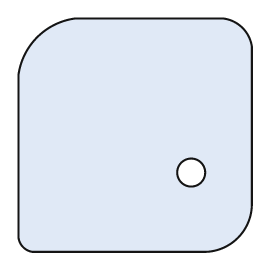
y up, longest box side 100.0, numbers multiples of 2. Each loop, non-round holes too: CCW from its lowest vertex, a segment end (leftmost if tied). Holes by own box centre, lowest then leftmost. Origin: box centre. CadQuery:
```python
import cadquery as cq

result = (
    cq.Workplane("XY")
    .moveTo(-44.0, -50.0)
    .lineTo(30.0, -50.0)
    .threePointArc((44.0, -44.0), (50.0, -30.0))
    .lineTo(50.0, 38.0)
    .threePointArc((46.0, 46.0), (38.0, 50.0))
    .lineTo(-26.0, 50.0)
    .threePointArc((-42.0, 42.0), (-50.0, 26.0))
    .lineTo(-50.0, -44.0)
    .threePointArc((-48.0, -48.0), (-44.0, -50.0))
    .close()
    .moveTo(24.0, -16.0)
    .circle(6.0)
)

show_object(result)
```